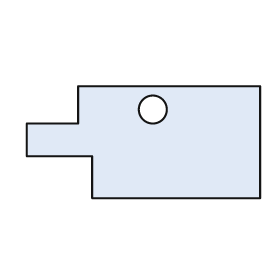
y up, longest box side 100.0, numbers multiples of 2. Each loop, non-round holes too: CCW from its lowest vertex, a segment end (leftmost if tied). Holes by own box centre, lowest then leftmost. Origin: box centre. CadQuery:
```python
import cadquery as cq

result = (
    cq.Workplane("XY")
    .moveTo(-22.0, -24.0)
    .lineTo(50.0, -24.0)
    .lineTo(50.0, 24.0)
    .lineTo(-28.0, 24.0)
    .lineTo(-28.0, 8.0)
    .lineTo(-50.0, 8.0)
    .lineTo(-50.0, -6.0)
    .lineTo(-22.0, -6.0)
    .close()
    .moveTo(4.0, 14.0)
    .circle(6.0)
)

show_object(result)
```